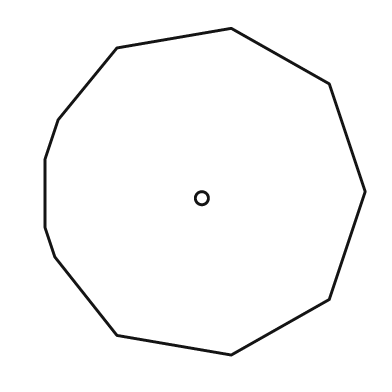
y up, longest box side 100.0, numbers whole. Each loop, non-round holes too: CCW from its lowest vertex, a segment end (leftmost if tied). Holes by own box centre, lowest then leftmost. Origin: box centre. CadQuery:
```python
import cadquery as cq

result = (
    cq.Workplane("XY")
    .moveTo(8.0, -50.0)
    .lineTo(38.0, -33.0)
    .lineTo(49.0, 0.0)
    .lineTo(38.0, 33.0)
    .lineTo(8.0, 50.0)
    .lineTo(-27.0, 44.0)
    .lineTo(-45.0, 22.0)
    .lineTo(-49.0, 10.0)
    .lineTo(-49.0, -11.0)
    .lineTo(-46.0, -20.0)
    .lineTo(-27.0, -44.0)
    .close()
    .moveTo(-1.0, -2.0)
    .circle(2.0)
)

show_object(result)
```